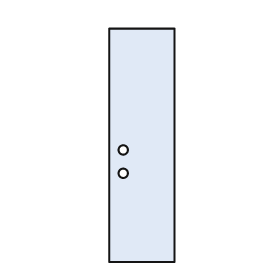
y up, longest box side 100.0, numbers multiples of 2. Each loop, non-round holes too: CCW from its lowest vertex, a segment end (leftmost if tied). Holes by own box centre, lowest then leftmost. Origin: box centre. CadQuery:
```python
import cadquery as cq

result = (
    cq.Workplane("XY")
    .moveTo(-14.0, -50.0)
    .lineTo(14.0, -50.0)
    .lineTo(14.0, 50.0)
    .lineTo(-14.0, 50.0)
    .close()
    .moveTo(-8.0, -12.0)
    .circle(2.0)
    .moveTo(-8.0, -2.0)
    .circle(2.0)
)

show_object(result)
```